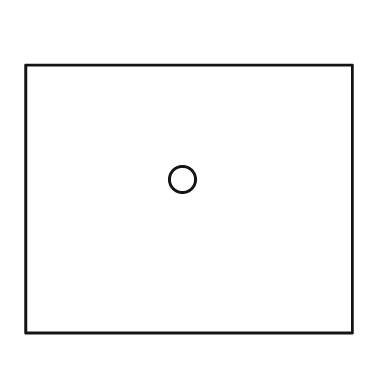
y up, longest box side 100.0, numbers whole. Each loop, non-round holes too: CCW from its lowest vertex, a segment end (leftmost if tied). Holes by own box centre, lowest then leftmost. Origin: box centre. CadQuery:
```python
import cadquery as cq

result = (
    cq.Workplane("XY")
    .moveTo(-50.0, -41.0)
    .lineTo(50.0, -41.0)
    .lineTo(50.0, 41.0)
    .lineTo(-50.0, 41.0)
    .close()
    .moveTo(-2.0, 6.0)
    .circle(4.0)
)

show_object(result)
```